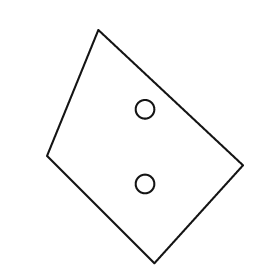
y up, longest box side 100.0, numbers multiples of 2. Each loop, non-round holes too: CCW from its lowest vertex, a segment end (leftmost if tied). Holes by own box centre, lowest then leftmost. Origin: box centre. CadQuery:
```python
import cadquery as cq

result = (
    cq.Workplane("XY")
    .moveTo(4.0, -50.0)
    .lineTo(42.0, -8.0)
    .lineTo(-20.0, 50.0)
    .lineTo(-42.0, -4.0)
    .close()
    .moveTo(0.0, -16.0)
    .circle(4.0)
    .moveTo(0.0, 16.0)
    .circle(4.0)
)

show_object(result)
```